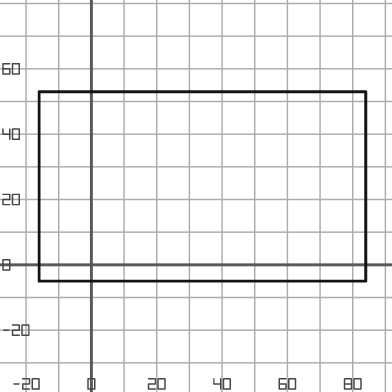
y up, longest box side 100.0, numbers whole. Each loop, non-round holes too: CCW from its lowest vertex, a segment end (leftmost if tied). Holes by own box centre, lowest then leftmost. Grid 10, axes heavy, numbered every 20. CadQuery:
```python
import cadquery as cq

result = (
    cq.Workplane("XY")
    .moveTo(-16.0, -5.0)
    .lineTo(84.0, -5.0)
    .lineTo(84.0, 53.0)
    .lineTo(-16.0, 53.0)
    .close()
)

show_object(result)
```